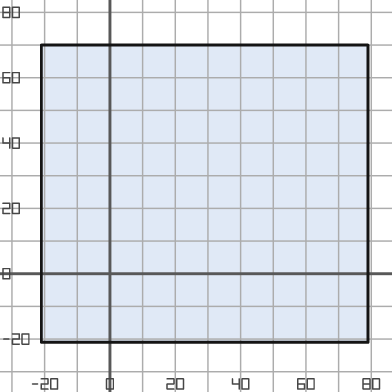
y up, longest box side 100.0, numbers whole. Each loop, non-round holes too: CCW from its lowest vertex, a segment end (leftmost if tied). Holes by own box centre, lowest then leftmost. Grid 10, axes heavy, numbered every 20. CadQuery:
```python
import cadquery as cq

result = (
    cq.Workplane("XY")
    .moveTo(-21.0, -21.0)
    .lineTo(79.0, -21.0)
    .lineTo(79.0, 70.0)
    .lineTo(-21.0, 70.0)
    .close()
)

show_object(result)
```